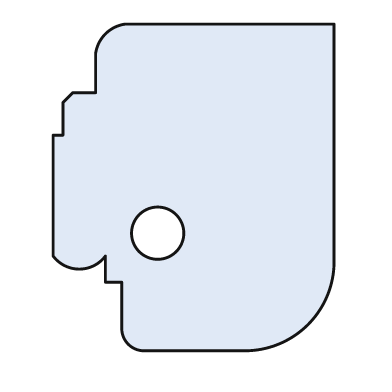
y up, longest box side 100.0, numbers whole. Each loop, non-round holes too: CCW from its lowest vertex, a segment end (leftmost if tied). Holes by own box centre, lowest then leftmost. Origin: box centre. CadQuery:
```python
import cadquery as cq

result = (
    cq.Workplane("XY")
    .moveTo(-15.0, -50.0)
    .lineTo(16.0, -50.0)
    .threePointArc((35.0, -42.0), (43.0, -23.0))
    .lineTo(43.0, 50.0)
    .lineTo(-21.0, 50.0)
    .threePointArc((-27.0, 47.0), (-30.0, 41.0))
    .lineTo(-30.0, 29.0)
    .lineTo(-37.0, 29.0)
    .lineTo(-40.0, 26.0)
    .lineTo(-40.0, 16.0)
    .lineTo(-43.0, 16.0)
    .lineTo(-43.0, -21.0)
    .threePointArc((-35.0, -25.0), (-27.0, -21.0))
    .lineTo(-27.0, -29.0)
    .lineTo(-22.0, -29.0)
    .lineTo(-22.0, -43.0)
    .threePointArc((-20.0, -48.0), (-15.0, -50.0))
    .close()
    .moveTo(-11.0, -14.0)
    .circle(8.0)
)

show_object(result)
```